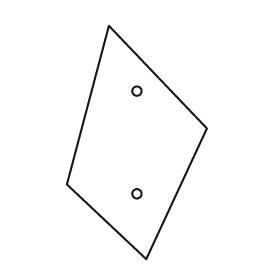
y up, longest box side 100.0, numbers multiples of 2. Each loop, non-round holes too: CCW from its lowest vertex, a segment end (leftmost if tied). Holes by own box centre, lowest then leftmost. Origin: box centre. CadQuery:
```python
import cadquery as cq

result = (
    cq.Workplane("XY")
    .moveTo(4.0, -50.0)
    .lineTo(30.0, 6.0)
    .lineTo(-12.0, 50.0)
    .lineTo(-30.0, -18.0)
    .close()
    .moveTo(0.0, -22.0)
    .circle(2.0)
    .moveTo(0.0, 22.0)
    .circle(2.0)
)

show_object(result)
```